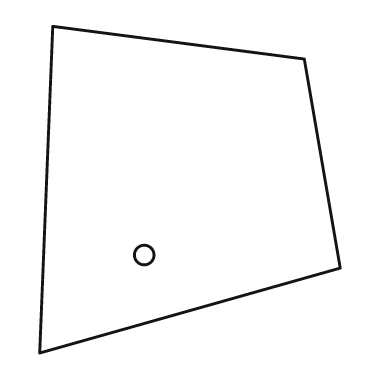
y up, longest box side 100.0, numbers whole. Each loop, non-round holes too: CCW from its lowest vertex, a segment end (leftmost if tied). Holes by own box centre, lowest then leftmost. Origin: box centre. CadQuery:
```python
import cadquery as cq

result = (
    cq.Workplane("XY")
    .moveTo(-46.0, -50.0)
    .lineTo(46.0, -24.0)
    .lineTo(35.0, 40.0)
    .lineTo(-42.0, 50.0)
    .close()
    .moveTo(-14.0, -20.0)
    .circle(3.0)
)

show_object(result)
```